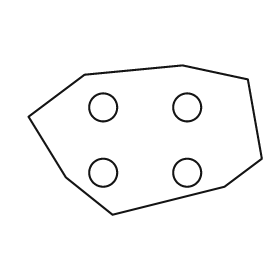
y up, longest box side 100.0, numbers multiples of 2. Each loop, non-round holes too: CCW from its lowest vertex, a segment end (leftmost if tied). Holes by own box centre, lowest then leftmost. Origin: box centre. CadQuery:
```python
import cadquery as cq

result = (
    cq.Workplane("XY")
    .moveTo(-14.0, -32.0)
    .lineTo(34.0, -20.0)
    .lineTo(50.0, -8.0)
    .lineTo(44.0, 26.0)
    .lineTo(16.0, 32.0)
    .lineTo(-26.0, 28.0)
    .lineTo(-50.0, 10.0)
    .lineTo(-34.0, -16.0)
    .close()
    .moveTo(-18.0, -14.0)
    .circle(6.0)
    .moveTo(18.0, -14.0)
    .circle(6.0)
    .moveTo(-18.0, 14.0)
    .circle(6.0)
    .moveTo(18.0, 14.0)
    .circle(6.0)
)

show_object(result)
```